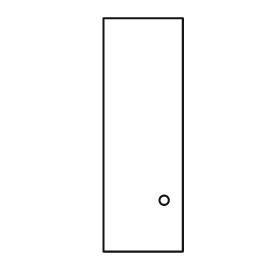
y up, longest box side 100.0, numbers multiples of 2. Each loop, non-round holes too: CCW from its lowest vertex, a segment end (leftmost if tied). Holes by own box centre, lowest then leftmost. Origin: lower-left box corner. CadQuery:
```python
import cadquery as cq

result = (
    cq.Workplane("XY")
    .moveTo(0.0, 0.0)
    .lineTo(34.0, 0.0)
    .lineTo(34.0, 100.0)
    .lineTo(0.0, 100.0)
    .close()
    .moveTo(26.0, 22.0)
    .circle(2.0)
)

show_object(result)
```